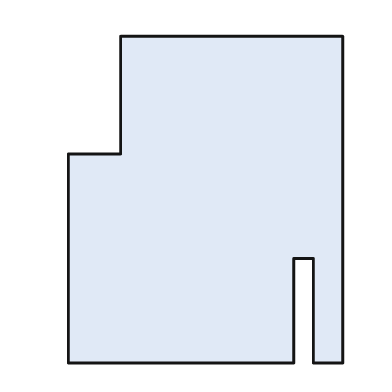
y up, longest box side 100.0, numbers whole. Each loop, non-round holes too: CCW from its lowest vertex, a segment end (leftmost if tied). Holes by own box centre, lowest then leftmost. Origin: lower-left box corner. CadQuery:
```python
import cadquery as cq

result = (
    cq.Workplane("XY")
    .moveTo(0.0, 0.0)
    .lineTo(69.0, 0.0)
    .lineTo(69.0, 32.0)
    .lineTo(75.0, 32.0)
    .lineTo(75.0, 0.0)
    .lineTo(84.0, 0.0)
    .lineTo(84.0, 100.0)
    .lineTo(16.0, 100.0)
    .lineTo(16.0, 64.0)
    .lineTo(0.0, 64.0)
    .close()
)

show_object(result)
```